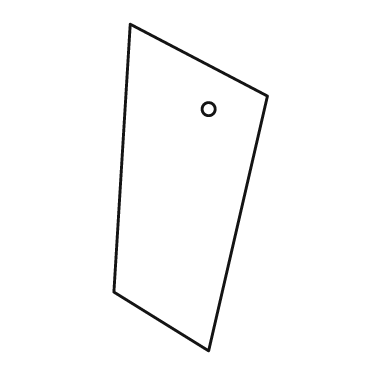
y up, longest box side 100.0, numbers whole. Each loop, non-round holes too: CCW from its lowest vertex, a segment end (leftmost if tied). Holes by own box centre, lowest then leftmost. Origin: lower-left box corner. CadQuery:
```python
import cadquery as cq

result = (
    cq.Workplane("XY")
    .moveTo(29.0, 0.0)
    .lineTo(47.0, 78.0)
    .lineTo(5.0, 100.0)
    .lineTo(0.0, 18.0)
    .close()
    .moveTo(29.0, 74.0)
    .circle(2.0)
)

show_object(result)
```